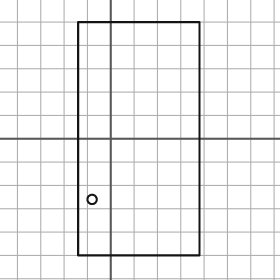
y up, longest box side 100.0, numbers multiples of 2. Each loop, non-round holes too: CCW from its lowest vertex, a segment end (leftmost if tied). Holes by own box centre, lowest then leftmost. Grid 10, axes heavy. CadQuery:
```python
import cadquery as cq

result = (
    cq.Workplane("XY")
    .moveTo(-14.0, -50.0)
    .lineTo(38.0, -50.0)
    .lineTo(38.0, 50.0)
    .lineTo(-14.0, 50.0)
    .close()
    .moveTo(-8.0, -26.0)
    .circle(2.0)
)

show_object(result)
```